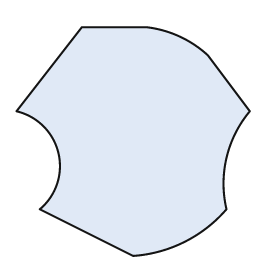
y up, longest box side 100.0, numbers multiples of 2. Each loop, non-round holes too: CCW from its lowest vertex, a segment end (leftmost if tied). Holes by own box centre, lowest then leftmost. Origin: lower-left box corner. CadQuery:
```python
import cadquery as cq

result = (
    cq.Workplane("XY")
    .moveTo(50.0, 0.0)
    .threePointArc((72.0, 6.0), (90.0, 20.0))
    .threePointArc((90.0, 42.0), (100.0, 62.0))
    .lineTo(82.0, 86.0)
    .threePointArc((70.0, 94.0), (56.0, 98.0))
    .lineTo(28.0, 98.0)
    .lineTo(0.0, 62.0)
    .threePointArc((18.0, 44.0), (10.0, 20.0))
    .close()
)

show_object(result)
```